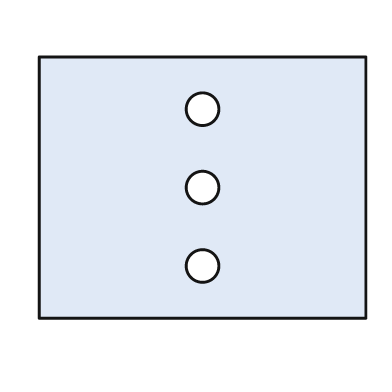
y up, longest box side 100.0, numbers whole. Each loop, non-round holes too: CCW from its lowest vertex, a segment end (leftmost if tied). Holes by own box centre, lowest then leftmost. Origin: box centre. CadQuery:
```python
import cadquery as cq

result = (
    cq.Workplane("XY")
    .moveTo(-50.0, -40.0)
    .lineTo(50.0, -40.0)
    .lineTo(50.0, 40.0)
    .lineTo(-50.0, 40.0)
    .close()
    .moveTo(0.0, -24.0)
    .circle(5.0)
    .moveTo(0.0, 0.0)
    .circle(5.0)
    .moveTo(0.0, 24.0)
    .circle(5.0)
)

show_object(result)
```